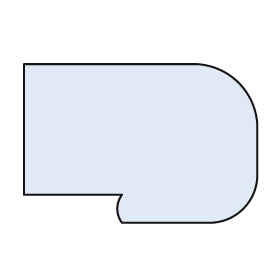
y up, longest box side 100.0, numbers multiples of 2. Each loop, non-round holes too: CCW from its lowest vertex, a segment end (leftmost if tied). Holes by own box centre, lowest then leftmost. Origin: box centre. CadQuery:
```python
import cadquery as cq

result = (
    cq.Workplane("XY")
    .moveTo(-8.0, -34.0)
    .lineTo(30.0, -34.0)
    .threePointArc((44.0, -28.0), (50.0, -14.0))
    .lineTo(50.0, 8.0)
    .threePointArc((42.0, 26.0), (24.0, 34.0))
    .lineTo(-50.0, 34.0)
    .lineTo(-50.0, -22.0)
    .lineTo(-8.0, -22.0)
    .threePointArc((-10.0, -28.0), (-8.0, -34.0))
    .close()
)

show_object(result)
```